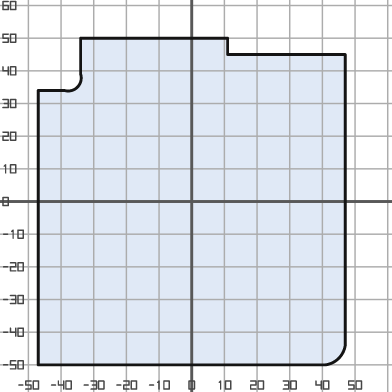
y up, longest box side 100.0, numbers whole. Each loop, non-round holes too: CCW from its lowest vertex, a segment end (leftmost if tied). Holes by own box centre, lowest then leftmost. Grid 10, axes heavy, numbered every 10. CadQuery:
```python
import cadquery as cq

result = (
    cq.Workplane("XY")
    .moveTo(-47.0, -50.0)
    .lineTo(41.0, -50.0)
    .threePointArc((45.0, -48.0), (47.0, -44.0))
    .lineTo(47.0, 45.0)
    .lineTo(11.0, 45.0)
    .lineTo(11.0, 50.0)
    .lineTo(-34.0, 50.0)
    .lineTo(-34.0, 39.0)
    .threePointArc((-35.0, 35.0), (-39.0, 34.0))
    .lineTo(-47.0, 34.0)
    .close()
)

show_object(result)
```